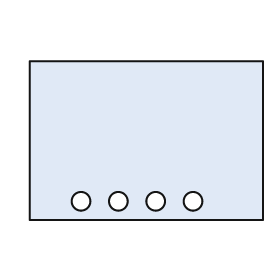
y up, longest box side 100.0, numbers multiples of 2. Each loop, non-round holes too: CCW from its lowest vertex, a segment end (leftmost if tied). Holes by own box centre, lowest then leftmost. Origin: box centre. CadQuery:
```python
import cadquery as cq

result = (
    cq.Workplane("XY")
    .moveTo(-50.0, -34.0)
    .lineTo(50.0, -34.0)
    .lineTo(50.0, 34.0)
    .lineTo(-50.0, 34.0)
    .close()
    .moveTo(-28.0, -26.0)
    .circle(4.0)
    .moveTo(-12.0, -26.0)
    .circle(4.0)
    .moveTo(4.0, -26.0)
    .circle(4.0)
    .moveTo(20.0, -26.0)
    .circle(4.0)
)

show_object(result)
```